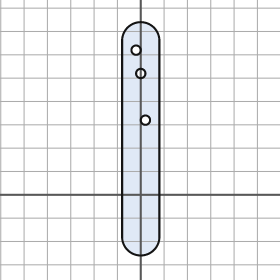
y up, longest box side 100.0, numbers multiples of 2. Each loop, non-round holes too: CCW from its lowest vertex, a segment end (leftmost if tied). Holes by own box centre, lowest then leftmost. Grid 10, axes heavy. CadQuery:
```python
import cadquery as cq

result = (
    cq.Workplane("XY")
    .moveTo(-8.0, -18.0)
    .threePointArc((0.0, -26.0), (8.0, -18.0))
    .lineTo(8.0, 66.0)
    .threePointArc((0.0, 74.0), (-8.0, 66.0))
    .close()
    .moveTo(2.0, 32.0)
    .circle(2.0)
    .moveTo(0.0, 52.0)
    .circle(2.0)
    .moveTo(-2.0, 62.0)
    .circle(2.0)
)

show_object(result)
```